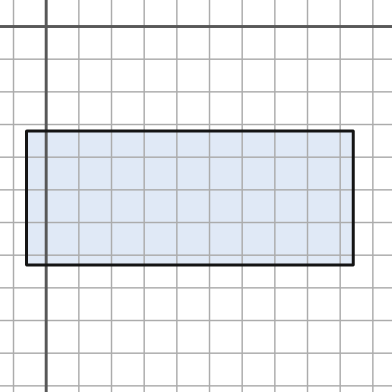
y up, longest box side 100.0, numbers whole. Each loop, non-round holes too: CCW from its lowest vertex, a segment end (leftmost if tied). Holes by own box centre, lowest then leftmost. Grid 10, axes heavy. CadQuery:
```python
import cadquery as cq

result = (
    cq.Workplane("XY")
    .moveTo(-6.0, -73.0)
    .lineTo(94.0, -73.0)
    .lineTo(94.0, -32.0)
    .lineTo(-6.0, -32.0)
    .close()
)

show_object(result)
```